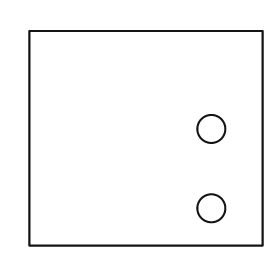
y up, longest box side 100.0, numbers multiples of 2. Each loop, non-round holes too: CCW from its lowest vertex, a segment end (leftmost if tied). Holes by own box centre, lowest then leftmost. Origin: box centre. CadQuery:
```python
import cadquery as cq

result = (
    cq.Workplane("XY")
    .moveTo(-50.0, -46.0)
    .lineTo(50.0, -46.0)
    .lineTo(50.0, 46.0)
    .lineTo(-50.0, 46.0)
    .close()
    .moveTo(28.0, -30.0)
    .circle(6.0)
    .moveTo(28.0, 4.0)
    .circle(6.0)
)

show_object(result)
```